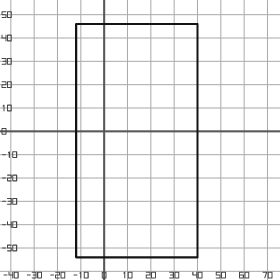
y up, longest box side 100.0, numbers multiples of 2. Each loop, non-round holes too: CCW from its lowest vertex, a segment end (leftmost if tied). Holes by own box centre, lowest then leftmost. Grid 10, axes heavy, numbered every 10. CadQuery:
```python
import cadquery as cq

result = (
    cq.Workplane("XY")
    .moveTo(-12.0, -54.0)
    .lineTo(40.0, -54.0)
    .lineTo(40.0, 46.0)
    .lineTo(-12.0, 46.0)
    .close()
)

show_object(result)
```